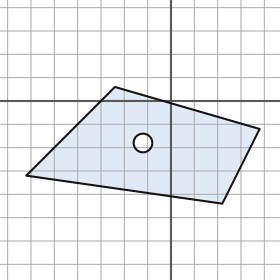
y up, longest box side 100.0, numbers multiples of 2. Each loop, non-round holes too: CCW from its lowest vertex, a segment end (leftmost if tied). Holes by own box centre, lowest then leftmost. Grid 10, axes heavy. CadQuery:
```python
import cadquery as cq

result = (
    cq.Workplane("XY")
    .moveTo(22.0, -44.0)
    .lineTo(38.0, -12.0)
    .lineTo(-24.0, 6.0)
    .lineTo(-62.0, -32.0)
    .close()
    .moveTo(-12.0, -18.0)
    .circle(4.0)
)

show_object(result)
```